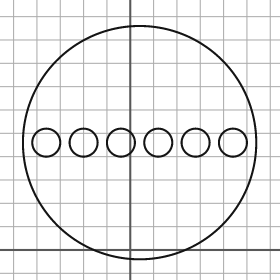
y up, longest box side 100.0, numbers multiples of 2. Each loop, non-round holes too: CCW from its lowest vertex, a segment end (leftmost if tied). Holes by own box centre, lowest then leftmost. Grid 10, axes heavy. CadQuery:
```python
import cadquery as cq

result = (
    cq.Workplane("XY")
    .moveTo(4.0, 46.0)
    .circle(50.0)
    .moveTo(-36.0, 46.0)
    .circle(6.0)
    .moveTo(-20.0, 46.0)
    .circle(6.0)
    .moveTo(-4.0, 46.0)
    .circle(6.0)
    .moveTo(12.0, 46.0)
    .circle(6.0)
    .moveTo(28.0, 46.0)
    .circle(6.0)
    .moveTo(44.0, 46.0)
    .circle(6.0)
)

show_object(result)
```